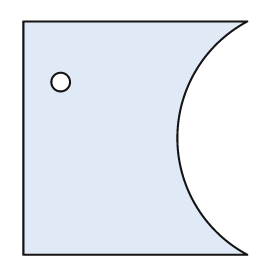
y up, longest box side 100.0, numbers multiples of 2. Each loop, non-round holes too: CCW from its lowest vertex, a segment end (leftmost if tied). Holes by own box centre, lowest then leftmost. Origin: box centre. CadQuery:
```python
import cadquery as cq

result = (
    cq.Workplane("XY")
    .moveTo(-48.0, -50.0)
    .lineTo(48.0, -50.0)
    .threePointArc((18.0, 0.0), (48.0, 50.0))
    .lineTo(-48.0, 50.0)
    .close()
    .moveTo(-32.0, 24.0)
    .circle(4.0)
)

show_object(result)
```